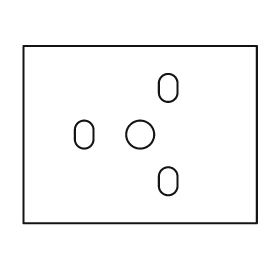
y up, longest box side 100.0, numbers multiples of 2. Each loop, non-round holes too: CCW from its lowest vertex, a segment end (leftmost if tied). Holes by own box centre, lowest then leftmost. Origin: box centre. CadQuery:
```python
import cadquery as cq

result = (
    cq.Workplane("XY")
    .moveTo(-50.0, -38.0)
    .lineTo(50.0, -38.0)
    .lineTo(50.0, 38.0)
    .lineTo(-50.0, 38.0)
    .close()
    .moveTo(8.0, -22.0)
    .threePointArc((12.0, -26.0), (16.0, -22.0))
    .lineTo(16.0, -18.0)
    .threePointArc((12.0, -14.0), (8.0, -18.0))
    .close()
    .moveTo(-28.0, -2.0)
    .threePointArc((-24.0, -6.0), (-20.0, -2.0))
    .lineTo(-20.0, 2.0)
    .threePointArc((-24.0, 6.0), (-28.0, 2.0))
    .close()
    .moveTo(0.0, 0.0)
    .circle(6.0)
    .moveTo(8.0, 18.0)
    .threePointArc((12.0, 14.0), (16.0, 18.0))
    .lineTo(16.0, 22.0)
    .threePointArc((12.0, 26.0), (8.0, 22.0))
    .close()
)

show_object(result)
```